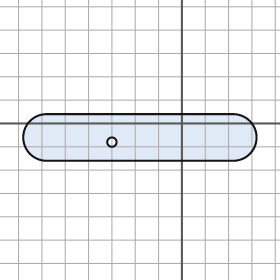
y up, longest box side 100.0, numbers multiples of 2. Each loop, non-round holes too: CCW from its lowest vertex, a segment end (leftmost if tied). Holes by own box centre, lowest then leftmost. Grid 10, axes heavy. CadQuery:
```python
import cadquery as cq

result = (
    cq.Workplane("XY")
    .moveTo(-58.0, -16.0)
    .lineTo(22.0, -16.0)
    .threePointArc((32.0, -6.0), (22.0, 4.0))
    .lineTo(-58.0, 4.0)
    .threePointArc((-68.0, -6.0), (-58.0, -16.0))
    .close()
    .moveTo(-30.0, -8.0)
    .circle(2.0)
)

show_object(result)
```